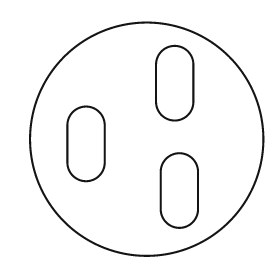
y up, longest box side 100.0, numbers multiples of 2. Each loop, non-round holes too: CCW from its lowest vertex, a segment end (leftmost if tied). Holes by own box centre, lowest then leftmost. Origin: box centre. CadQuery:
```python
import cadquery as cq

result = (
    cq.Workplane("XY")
    .moveTo(0.0, 0.0)
    .circle(50.0)
    .moveTo(6.0, -30.0)
    .threePointArc((14.0, -38.0), (22.0, -30.0))
    .lineTo(22.0, -14.0)
    .threePointArc((14.0, -6.0), (6.0, -14.0))
    .close()
    .moveTo(-34.0, -10.0)
    .threePointArc((-26.0, -18.0), (-18.0, -10.0))
    .lineTo(-18.0, 6.0)
    .threePointArc((-26.0, 14.0), (-34.0, 6.0))
    .close()
    .moveTo(4.0, 16.0)
    .threePointArc((12.0, 8.0), (20.0, 16.0))
    .lineTo(20.0, 32.0)
    .threePointArc((12.0, 40.0), (4.0, 32.0))
    .close()
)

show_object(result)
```